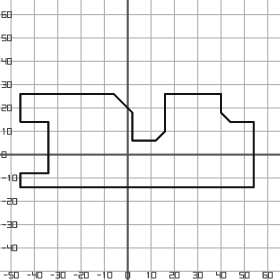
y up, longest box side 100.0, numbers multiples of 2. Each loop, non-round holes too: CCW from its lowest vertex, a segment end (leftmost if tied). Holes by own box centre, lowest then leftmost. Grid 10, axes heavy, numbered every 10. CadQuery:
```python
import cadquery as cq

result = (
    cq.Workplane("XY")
    .moveTo(-46.0, -14.0)
    .lineTo(54.0, -14.0)
    .lineTo(54.0, 14.0)
    .lineTo(44.0, 14.0)
    .lineTo(40.0, 18.0)
    .lineTo(40.0, 26.0)
    .lineTo(16.0, 26.0)
    .lineTo(16.0, 10.0)
    .lineTo(12.0, 6.0)
    .lineTo(2.0, 6.0)
    .lineTo(2.0, 18.0)
    .lineTo(-6.0, 26.0)
    .lineTo(-46.0, 26.0)
    .lineTo(-46.0, 14.0)
    .lineTo(-34.0, 14.0)
    .lineTo(-34.0, -8.0)
    .lineTo(-46.0, -8.0)
    .close()
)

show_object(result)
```